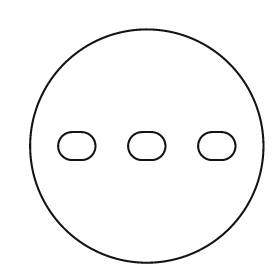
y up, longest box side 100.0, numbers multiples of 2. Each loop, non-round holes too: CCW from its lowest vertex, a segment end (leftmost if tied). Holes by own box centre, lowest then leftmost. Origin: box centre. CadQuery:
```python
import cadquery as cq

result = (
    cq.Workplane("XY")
    .moveTo(0.0, 0.0)
    .circle(50.0)
    .moveTo(-32.0, -6.0)
    .lineTo(-28.0, -6.0)
    .threePointArc((-22.0, 0.0), (-28.0, 6.0))
    .lineTo(-32.0, 6.0)
    .threePointArc((-38.0, 0.0), (-32.0, -6.0))
    .close()
    .moveTo(-2.0, -6.0)
    .lineTo(2.0, -6.0)
    .threePointArc((8.0, 0.0), (2.0, 6.0))
    .lineTo(-2.0, 6.0)
    .threePointArc((-8.0, 0.0), (-2.0, -6.0))
    .close()
    .moveTo(28.0, -6.0)
    .lineTo(32.0, -6.0)
    .threePointArc((38.0, 0.0), (32.0, 6.0))
    .lineTo(28.0, 6.0)
    .threePointArc((22.0, 0.0), (28.0, -6.0))
    .close()
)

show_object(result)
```